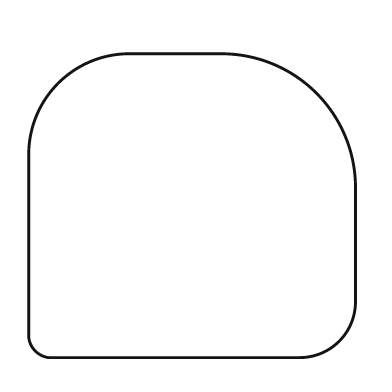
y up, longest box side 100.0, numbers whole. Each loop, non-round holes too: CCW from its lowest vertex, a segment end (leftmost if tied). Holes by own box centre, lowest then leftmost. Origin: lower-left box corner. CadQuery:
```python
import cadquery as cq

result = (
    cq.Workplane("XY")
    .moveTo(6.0, 0.0)
    .lineTo(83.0, 0.0)
    .threePointArc((95.0, 5.0), (100.0, 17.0))
    .lineTo(100.0, 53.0)
    .threePointArc((88.0, 81.0), (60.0, 93.0))
    .lineTo(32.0, 93.0)
    .threePointArc((9.0, 84.0), (0.0, 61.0))
    .lineTo(0.0, 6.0)
    .threePointArc((2.0, 2.0), (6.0, 0.0))
    .close()
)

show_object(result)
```